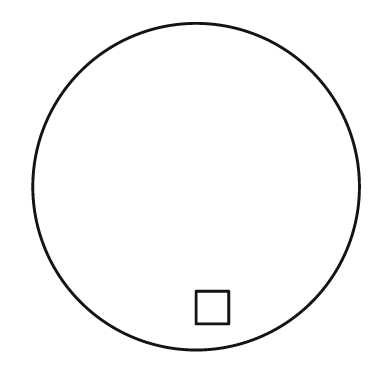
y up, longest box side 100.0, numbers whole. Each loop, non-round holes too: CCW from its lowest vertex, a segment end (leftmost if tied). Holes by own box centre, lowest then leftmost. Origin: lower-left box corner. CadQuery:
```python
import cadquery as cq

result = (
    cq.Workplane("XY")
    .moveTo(50.0, 50.0)
    .circle(50.0)
    .moveTo(50.0, 8.0)
    .lineTo(60.0, 8.0)
    .lineTo(60.0, 18.0)
    .lineTo(50.0, 18.0)
    .close()
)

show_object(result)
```